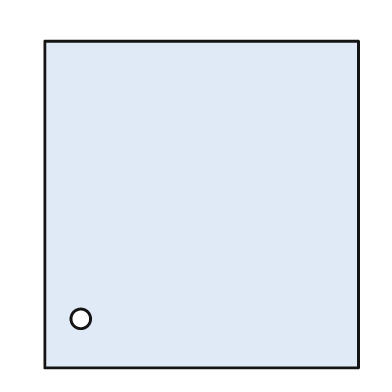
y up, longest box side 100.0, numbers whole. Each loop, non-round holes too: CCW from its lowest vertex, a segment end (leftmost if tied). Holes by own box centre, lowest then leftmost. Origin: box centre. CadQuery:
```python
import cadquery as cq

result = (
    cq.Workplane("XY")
    .moveTo(-48.0, -50.0)
    .lineTo(48.0, -50.0)
    .lineTo(48.0, 50.0)
    .lineTo(-48.0, 50.0)
    .close()
    .moveTo(-37.0, -35.0)
    .circle(3.0)
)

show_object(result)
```